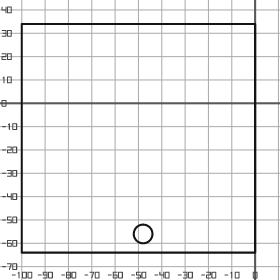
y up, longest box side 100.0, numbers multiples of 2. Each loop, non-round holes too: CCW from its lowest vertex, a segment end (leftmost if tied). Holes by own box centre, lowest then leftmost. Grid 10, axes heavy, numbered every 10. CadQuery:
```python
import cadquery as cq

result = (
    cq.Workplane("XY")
    .moveTo(-100.0, -64.0)
    .lineTo(0.0, -64.0)
    .lineTo(0.0, 34.0)
    .lineTo(-100.0, 34.0)
    .close()
    .moveTo(-48.0, -56.0)
    .circle(4.0)
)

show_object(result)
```